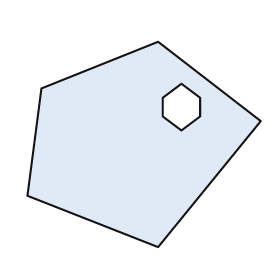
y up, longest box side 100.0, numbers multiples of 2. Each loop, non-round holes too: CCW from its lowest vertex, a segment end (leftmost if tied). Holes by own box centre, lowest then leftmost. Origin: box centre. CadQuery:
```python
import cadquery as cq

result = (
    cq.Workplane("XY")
    .moveTo(6.0, -44.0)
    .lineTo(50.0, 10.0)
    .lineTo(6.0, 44.0)
    .lineTo(-44.0, 24.0)
    .lineTo(-50.0, -22.0)
    .close()
    .moveTo(16.0, 6.0)
    .lineTo(24.0, 12.0)
    .lineTo(24.0, 20.0)
    .lineTo(16.0, 26.0)
    .lineTo(8.0, 20.0)
    .lineTo(8.0, 12.0)
    .close()
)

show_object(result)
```